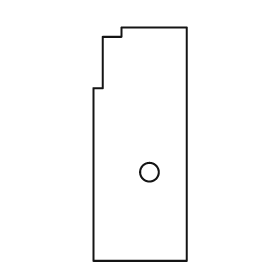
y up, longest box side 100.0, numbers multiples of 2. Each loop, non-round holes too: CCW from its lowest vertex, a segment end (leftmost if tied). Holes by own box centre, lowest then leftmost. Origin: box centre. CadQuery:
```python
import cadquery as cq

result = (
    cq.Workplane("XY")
    .moveTo(-20.0, -50.0)
    .lineTo(20.0, -50.0)
    .lineTo(20.0, 50.0)
    .lineTo(-8.0, 50.0)
    .lineTo(-8.0, 46.0)
    .lineTo(-16.0, 46.0)
    .lineTo(-16.0, 24.0)
    .lineTo(-20.0, 24.0)
    .close()
    .moveTo(4.0, -12.0)
    .circle(4.0)
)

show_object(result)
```